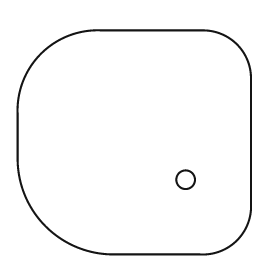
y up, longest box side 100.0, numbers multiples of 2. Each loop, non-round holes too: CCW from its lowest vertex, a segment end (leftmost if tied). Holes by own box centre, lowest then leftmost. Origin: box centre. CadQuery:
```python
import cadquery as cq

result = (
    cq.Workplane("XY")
    .moveTo(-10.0, -48.0)
    .lineTo(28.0, -48.0)
    .threePointArc((44.0, -42.0), (50.0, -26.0))
    .lineTo(50.0, 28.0)
    .threePointArc((44.0, 42.0), (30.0, 48.0))
    .lineTo(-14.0, 48.0)
    .threePointArc((-40.0, 38.0), (-50.0, 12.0))
    .lineTo(-50.0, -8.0)
    .threePointArc((-38.0, -36.0), (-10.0, -48.0))
    .close()
    .moveTo(22.0, -16.0)
    .circle(4.0)
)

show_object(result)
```